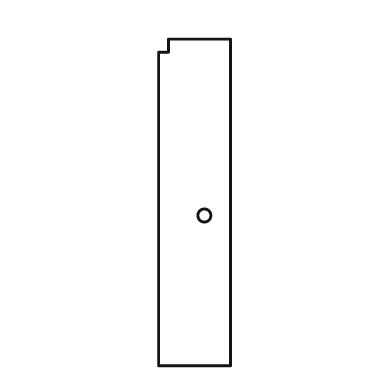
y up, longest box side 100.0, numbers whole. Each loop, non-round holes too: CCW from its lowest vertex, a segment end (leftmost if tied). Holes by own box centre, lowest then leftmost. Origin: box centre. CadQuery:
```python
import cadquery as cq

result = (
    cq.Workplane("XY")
    .moveTo(-11.0, -50.0)
    .lineTo(11.0, -50.0)
    .lineTo(11.0, 50.0)
    .lineTo(-8.0, 50.0)
    .lineTo(-8.0, 46.0)
    .lineTo(-11.0, 46.0)
    .close()
    .moveTo(3.0, -4.0)
    .circle(2.0)
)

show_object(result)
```